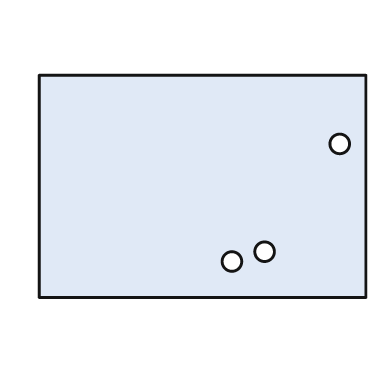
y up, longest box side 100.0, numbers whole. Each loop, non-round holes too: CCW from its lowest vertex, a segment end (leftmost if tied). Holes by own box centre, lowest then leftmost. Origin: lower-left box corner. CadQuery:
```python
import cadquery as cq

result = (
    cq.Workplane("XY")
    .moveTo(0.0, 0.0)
    .lineTo(100.0, 0.0)
    .lineTo(100.0, 68.0)
    .lineTo(0.0, 68.0)
    .close()
    .moveTo(59.0, 11.0)
    .circle(3.0)
    .moveTo(69.0, 14.0)
    .circle(3.0)
    .moveTo(92.0, 47.0)
    .circle(3.0)
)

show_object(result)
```